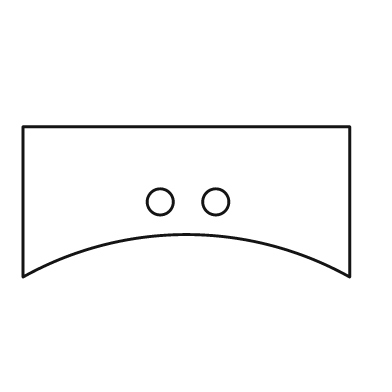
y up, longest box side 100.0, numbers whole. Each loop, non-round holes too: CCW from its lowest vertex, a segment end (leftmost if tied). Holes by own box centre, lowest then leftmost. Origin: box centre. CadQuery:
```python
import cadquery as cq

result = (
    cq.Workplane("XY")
    .moveTo(-50.0, -23.0)
    .threePointArc((0.0, -10.0), (50.0, -23.0))
    .lineTo(50.0, 23.0)
    .lineTo(-50.0, 23.0)
    .close()
    .moveTo(-8.0, 0.0)
    .circle(4.0)
    .moveTo(9.0, 0.0)
    .circle(4.0)
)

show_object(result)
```